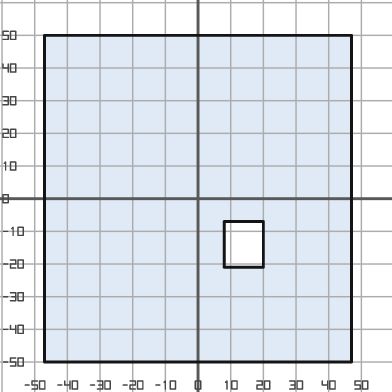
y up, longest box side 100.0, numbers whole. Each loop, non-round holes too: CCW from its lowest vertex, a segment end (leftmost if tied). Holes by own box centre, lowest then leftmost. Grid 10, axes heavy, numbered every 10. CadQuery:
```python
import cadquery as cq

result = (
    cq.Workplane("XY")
    .moveTo(-47.0, -50.0)
    .lineTo(47.0, -50.0)
    .lineTo(47.0, 50.0)
    .lineTo(-47.0, 50.0)
    .close()
    .moveTo(8.0, -21.0)
    .lineTo(20.0, -21.0)
    .lineTo(20.0, -7.0)
    .lineTo(8.0, -7.0)
    .close()
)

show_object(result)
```